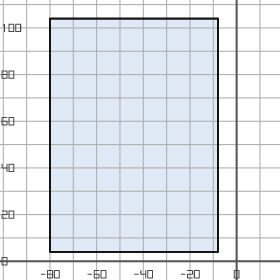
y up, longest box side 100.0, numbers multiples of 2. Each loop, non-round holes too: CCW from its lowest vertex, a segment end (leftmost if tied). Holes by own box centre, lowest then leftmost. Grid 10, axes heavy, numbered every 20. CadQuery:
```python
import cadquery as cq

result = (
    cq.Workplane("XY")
    .moveTo(-80.0, 4.0)
    .lineTo(-8.0, 4.0)
    .lineTo(-8.0, 104.0)
    .lineTo(-80.0, 104.0)
    .close()
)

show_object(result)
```